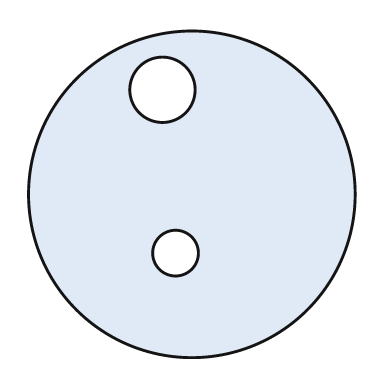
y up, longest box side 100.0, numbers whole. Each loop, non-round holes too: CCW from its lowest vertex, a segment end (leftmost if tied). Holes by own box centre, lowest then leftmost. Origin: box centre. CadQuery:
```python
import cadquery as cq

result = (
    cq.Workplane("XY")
    .moveTo(0.0, 0.0)
    .circle(50.0)
    .moveTo(-5.0, -18.0)
    .circle(7.0)
    .moveTo(-9.0, 32.0)
    .circle(10.0)
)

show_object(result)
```